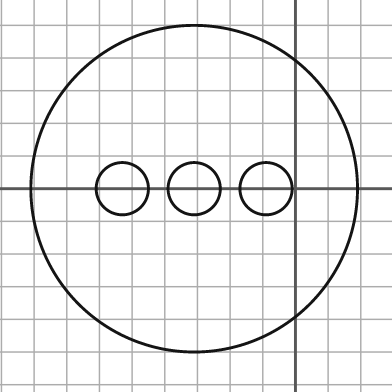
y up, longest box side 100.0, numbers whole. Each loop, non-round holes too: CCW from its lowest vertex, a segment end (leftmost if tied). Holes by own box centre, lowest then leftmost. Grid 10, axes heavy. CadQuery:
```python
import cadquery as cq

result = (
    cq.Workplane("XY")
    .moveTo(-31.0, 0.0)
    .circle(50.0)
    .moveTo(-53.0, 0.0)
    .circle(8.0)
    .moveTo(-31.0, 0.0)
    .circle(8.0)
    .moveTo(-9.0, 0.0)
    .circle(8.0)
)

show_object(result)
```